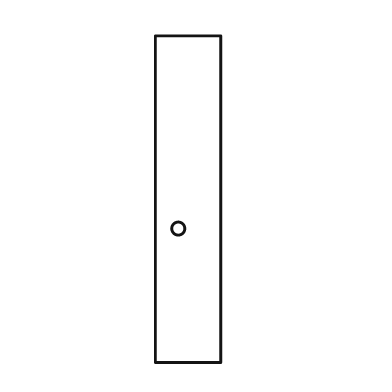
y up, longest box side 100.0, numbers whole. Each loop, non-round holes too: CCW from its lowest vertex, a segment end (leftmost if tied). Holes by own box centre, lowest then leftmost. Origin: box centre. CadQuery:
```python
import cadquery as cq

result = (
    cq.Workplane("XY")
    .moveTo(-10.0, -50.0)
    .lineTo(10.0, -50.0)
    .lineTo(10.0, 50.0)
    .lineTo(-10.0, 50.0)
    .close()
    .moveTo(-3.0, -9.0)
    .circle(2.0)
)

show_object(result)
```